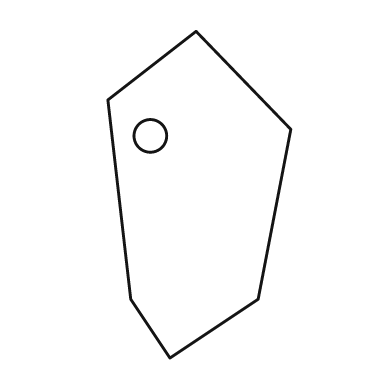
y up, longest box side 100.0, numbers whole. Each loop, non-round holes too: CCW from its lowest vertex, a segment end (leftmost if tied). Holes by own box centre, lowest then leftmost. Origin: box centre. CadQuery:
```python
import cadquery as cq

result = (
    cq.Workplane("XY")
    .moveTo(-9.0, -50.0)
    .lineTo(18.0, -32.0)
    .lineTo(28.0, 20.0)
    .lineTo(-1.0, 50.0)
    .lineTo(-28.0, 29.0)
    .lineTo(-21.0, -32.0)
    .close()
    .moveTo(-15.0, 18.0)
    .circle(5.0)
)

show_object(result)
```